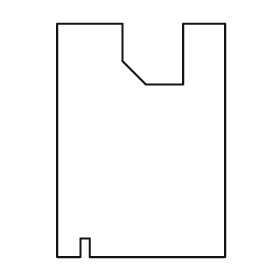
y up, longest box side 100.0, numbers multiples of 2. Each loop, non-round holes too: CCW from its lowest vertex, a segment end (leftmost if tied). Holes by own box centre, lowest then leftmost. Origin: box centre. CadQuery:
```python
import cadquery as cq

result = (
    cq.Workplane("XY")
    .moveTo(-36.0, -50.0)
    .lineTo(-26.0, -50.0)
    .lineTo(-26.0, -42.0)
    .lineTo(-22.0, -42.0)
    .lineTo(-22.0, -50.0)
    .lineTo(36.0, -50.0)
    .lineTo(36.0, 50.0)
    .lineTo(18.0, 50.0)
    .lineTo(18.0, 24.0)
    .lineTo(2.0, 24.0)
    .lineTo(-8.0, 34.0)
    .lineTo(-8.0, 50.0)
    .lineTo(-36.0, 50.0)
    .close()
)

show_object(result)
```